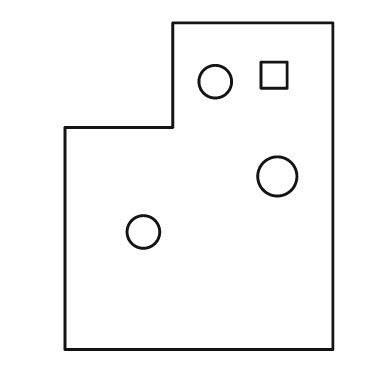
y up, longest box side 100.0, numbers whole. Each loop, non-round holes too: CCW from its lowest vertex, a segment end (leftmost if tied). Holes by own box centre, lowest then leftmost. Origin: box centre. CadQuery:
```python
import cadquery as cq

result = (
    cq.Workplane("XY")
    .moveTo(-41.0, -50.0)
    .lineTo(41.0, -50.0)
    .lineTo(41.0, 50.0)
    .lineTo(-8.0, 50.0)
    .lineTo(-8.0, 18.0)
    .lineTo(-41.0, 18.0)
    .close()
    .moveTo(-17.0, -14.0)
    .circle(5.0)
    .moveTo(24.0, 3.0)
    .circle(6.0)
    .moveTo(5.0, 32.0)
    .circle(5.0)
    .moveTo(19.0, 30.0)
    .lineTo(27.0, 30.0)
    .lineTo(27.0, 38.0)
    .lineTo(19.0, 38.0)
    .close()
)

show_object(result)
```